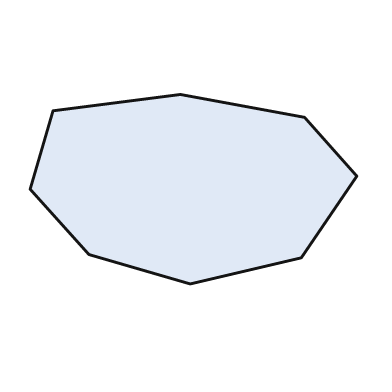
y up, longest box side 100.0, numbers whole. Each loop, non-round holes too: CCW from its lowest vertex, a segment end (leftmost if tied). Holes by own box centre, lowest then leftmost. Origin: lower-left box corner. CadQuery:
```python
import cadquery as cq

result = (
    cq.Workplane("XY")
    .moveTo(49.0, 0.0)
    .lineTo(83.0, 8.0)
    .lineTo(100.0, 33.0)
    .lineTo(84.0, 51.0)
    .lineTo(46.0, 58.0)
    .lineTo(7.0, 53.0)
    .lineTo(0.0, 29.0)
    .lineTo(18.0, 9.0)
    .close()
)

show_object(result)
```